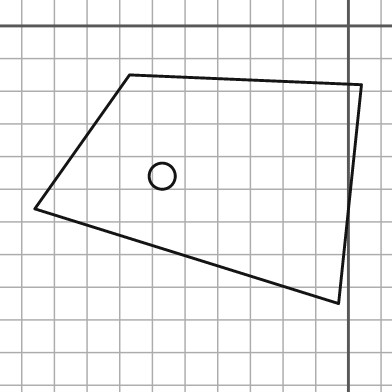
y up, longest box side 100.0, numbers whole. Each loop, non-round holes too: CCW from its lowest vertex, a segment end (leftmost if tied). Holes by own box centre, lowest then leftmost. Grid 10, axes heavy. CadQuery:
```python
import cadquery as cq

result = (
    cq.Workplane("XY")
    .moveTo(-3.0, -85.0)
    .lineTo(4.0, -18.0)
    .lineTo(-67.0, -15.0)
    .lineTo(-96.0, -56.0)
    .close()
    .moveTo(-57.0, -46.0)
    .circle(4.0)
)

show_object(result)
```